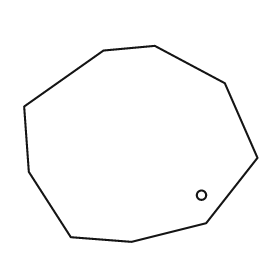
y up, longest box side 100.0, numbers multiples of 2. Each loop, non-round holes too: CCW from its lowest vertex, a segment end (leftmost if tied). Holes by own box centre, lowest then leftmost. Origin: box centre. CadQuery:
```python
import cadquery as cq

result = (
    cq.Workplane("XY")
    .moveTo(-4.0, -42.0)
    .lineTo(28.0, -34.0)
    .lineTo(50.0, -6.0)
    .lineTo(36.0, 26.0)
    .lineTo(6.0, 42.0)
    .lineTo(-16.0, 40.0)
    .lineTo(-50.0, 16.0)
    .lineTo(-48.0, -12.0)
    .lineTo(-30.0, -40.0)
    .close()
    .moveTo(26.0, -22.0)
    .circle(2.0)
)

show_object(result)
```